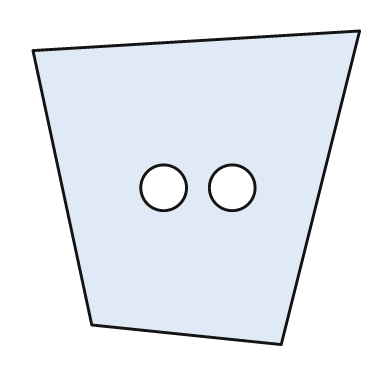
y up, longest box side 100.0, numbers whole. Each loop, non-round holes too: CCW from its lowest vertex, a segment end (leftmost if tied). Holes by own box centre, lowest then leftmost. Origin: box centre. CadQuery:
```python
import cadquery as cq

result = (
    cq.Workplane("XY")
    .moveTo(26.0, -48.0)
    .lineTo(50.0, 48.0)
    .lineTo(-50.0, 42.0)
    .lineTo(-32.0, -42.0)
    .close()
    .moveTo(-10.0, 0.0)
    .circle(7.0)
    .moveTo(11.0, 0.0)
    .circle(7.0)
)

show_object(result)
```